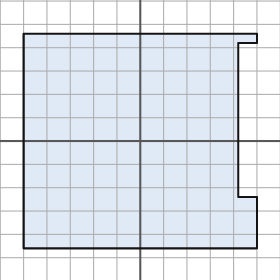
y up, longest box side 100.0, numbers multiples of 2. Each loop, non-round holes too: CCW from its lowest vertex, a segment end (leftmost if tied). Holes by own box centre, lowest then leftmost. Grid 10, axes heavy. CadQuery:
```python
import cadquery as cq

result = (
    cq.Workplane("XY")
    .moveTo(-50.0, -46.0)
    .lineTo(50.0, -46.0)
    .lineTo(50.0, -24.0)
    .lineTo(42.0, -24.0)
    .lineTo(42.0, 42.0)
    .lineTo(50.0, 42.0)
    .lineTo(50.0, 46.0)
    .lineTo(-50.0, 46.0)
    .close()
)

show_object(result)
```